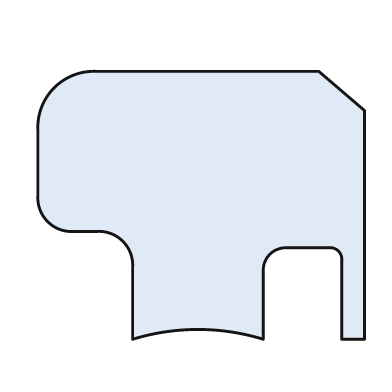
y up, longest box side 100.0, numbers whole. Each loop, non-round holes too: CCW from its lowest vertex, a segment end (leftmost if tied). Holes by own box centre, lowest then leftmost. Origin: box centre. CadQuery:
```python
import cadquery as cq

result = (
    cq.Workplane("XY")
    .moveTo(-21.0, -41.0)
    .threePointArc((-1.0, -38.0), (19.0, -41.0))
    .lineTo(19.0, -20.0)
    .threePointArc((21.0, -15.0), (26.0, -13.0))
    .lineTo(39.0, -13.0)
    .threePointArc((42.0, -14.0), (43.0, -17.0))
    .lineTo(43.0, -41.0)
    .lineTo(50.0, -41.0)
    .lineTo(50.0, 29.0)
    .lineTo(36.0, 41.0)
    .lineTo(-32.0, 41.0)
    .threePointArc((-45.0, 36.0), (-50.0, 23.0))
    .lineTo(-50.0, 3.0)
    .threePointArc((-47.0, -5.0), (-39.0, -8.0))
    .lineTo(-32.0, -8.0)
    .threePointArc((-24.0, -11.0), (-21.0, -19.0))
    .close()
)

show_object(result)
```